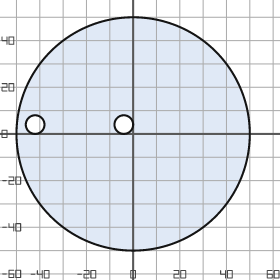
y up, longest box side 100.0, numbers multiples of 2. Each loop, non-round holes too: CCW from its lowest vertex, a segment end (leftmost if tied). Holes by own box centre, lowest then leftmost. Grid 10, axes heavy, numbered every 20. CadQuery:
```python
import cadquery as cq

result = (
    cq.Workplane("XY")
    .moveTo(0.0, 0.0)
    .circle(50.0)
    .moveTo(-42.0, 4.0)
    .circle(4.0)
    .moveTo(-4.0, 4.0)
    .circle(4.0)
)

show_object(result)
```